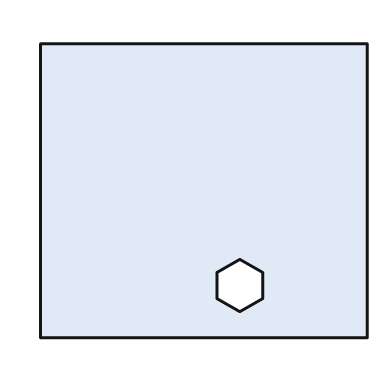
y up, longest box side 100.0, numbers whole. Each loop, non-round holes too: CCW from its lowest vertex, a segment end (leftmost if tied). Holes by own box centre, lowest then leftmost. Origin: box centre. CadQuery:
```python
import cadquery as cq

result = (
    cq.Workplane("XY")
    .moveTo(-50.0, -45.0)
    .lineTo(50.0, -45.0)
    .lineTo(50.0, 45.0)
    .lineTo(-50.0, 45.0)
    .close()
    .moveTo(11.0, -37.0)
    .lineTo(18.0, -33.0)
    .lineTo(18.0, -25.0)
    .lineTo(11.0, -21.0)
    .lineTo(4.0, -25.0)
    .lineTo(4.0, -33.0)
    .close()
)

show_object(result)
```